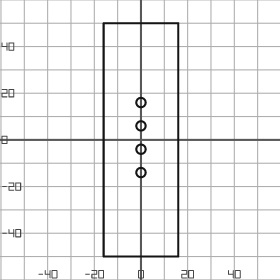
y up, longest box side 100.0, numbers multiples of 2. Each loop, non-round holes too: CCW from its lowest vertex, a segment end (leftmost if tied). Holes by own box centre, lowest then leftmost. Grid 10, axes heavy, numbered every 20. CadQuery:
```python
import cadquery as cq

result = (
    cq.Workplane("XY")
    .moveTo(-16.0, -50.0)
    .lineTo(16.0, -50.0)
    .lineTo(16.0, 50.0)
    .lineTo(-16.0, 50.0)
    .close()
    .moveTo(0.0, -14.0)
    .circle(2.0)
    .moveTo(0.0, -4.0)
    .circle(2.0)
    .moveTo(0.0, 6.0)
    .circle(2.0)
    .moveTo(0.0, 16.0)
    .circle(2.0)
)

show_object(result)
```